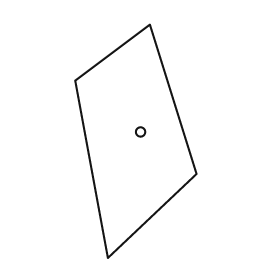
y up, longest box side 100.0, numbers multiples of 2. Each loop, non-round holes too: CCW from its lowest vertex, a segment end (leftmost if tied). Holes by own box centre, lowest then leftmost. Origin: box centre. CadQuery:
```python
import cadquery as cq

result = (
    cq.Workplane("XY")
    .moveTo(-12.0, -50.0)
    .lineTo(26.0, -14.0)
    .lineTo(6.0, 50.0)
    .lineTo(-26.0, 26.0)
    .close()
    .moveTo(2.0, 4.0)
    .circle(2.0)
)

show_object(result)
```